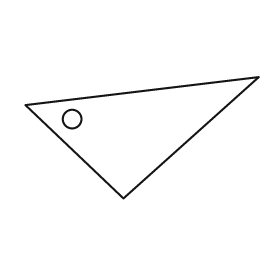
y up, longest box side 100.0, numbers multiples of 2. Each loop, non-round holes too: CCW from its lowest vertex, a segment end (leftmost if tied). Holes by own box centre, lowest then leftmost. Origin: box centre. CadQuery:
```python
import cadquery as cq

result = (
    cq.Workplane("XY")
    .moveTo(-8.0, -26.0)
    .lineTo(50.0, 26.0)
    .lineTo(-50.0, 14.0)
    .close()
    .moveTo(-30.0, 8.0)
    .circle(4.0)
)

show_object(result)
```